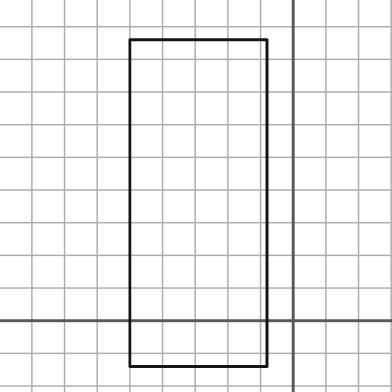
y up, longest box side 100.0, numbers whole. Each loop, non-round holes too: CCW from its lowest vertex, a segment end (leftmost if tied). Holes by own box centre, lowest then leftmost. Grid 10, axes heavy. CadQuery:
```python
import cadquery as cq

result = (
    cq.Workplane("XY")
    .moveTo(-50.0, -14.0)
    .lineTo(-8.0, -14.0)
    .lineTo(-8.0, 86.0)
    .lineTo(-50.0, 86.0)
    .close()
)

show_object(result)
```